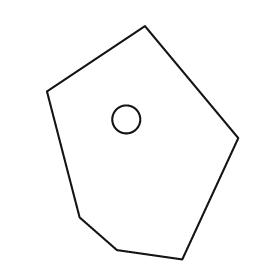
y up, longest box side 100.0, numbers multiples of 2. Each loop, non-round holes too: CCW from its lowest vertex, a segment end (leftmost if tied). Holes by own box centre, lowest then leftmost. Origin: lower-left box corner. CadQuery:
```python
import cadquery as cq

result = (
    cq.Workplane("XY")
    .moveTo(58.0, 0.0)
    .lineTo(82.0, 52.0)
    .lineTo(42.0, 100.0)
    .lineTo(0.0, 72.0)
    .lineTo(14.0, 18.0)
    .lineTo(30.0, 4.0)
    .close()
    .moveTo(34.0, 60.0)
    .circle(6.0)
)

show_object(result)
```